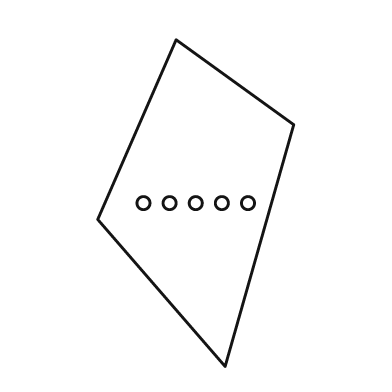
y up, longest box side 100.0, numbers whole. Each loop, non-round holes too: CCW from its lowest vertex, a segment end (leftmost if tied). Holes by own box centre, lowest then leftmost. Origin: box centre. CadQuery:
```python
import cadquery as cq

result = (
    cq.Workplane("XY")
    .moveTo(9.0, -50.0)
    .lineTo(30.0, 24.0)
    .lineTo(-6.0, 50.0)
    .lineTo(-30.0, -5.0)
    .close()
    .moveTo(-16.0, 0.0)
    .circle(2.0)
    .moveTo(-8.0, 0.0)
    .circle(2.0)
    .moveTo(0.0, 0.0)
    .circle(2.0)
    .moveTo(8.0, 0.0)
    .circle(2.0)
    .moveTo(16.0, 0.0)
    .circle(2.0)
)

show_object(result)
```